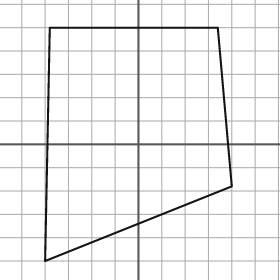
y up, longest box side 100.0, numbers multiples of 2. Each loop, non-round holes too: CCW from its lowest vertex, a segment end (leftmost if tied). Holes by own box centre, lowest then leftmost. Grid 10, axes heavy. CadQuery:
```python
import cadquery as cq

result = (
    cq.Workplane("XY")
    .moveTo(-40.0, -50.0)
    .lineTo(40.0, -18.0)
    .lineTo(34.0, 50.0)
    .lineTo(-38.0, 50.0)
    .close()
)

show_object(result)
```